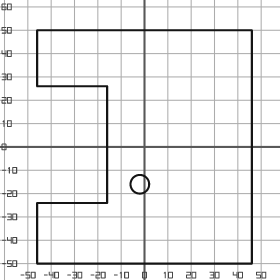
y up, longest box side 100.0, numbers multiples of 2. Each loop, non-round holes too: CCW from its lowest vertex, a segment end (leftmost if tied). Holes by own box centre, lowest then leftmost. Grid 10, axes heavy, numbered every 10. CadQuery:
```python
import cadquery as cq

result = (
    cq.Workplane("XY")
    .moveTo(-46.0, -50.0)
    .lineTo(46.0, -50.0)
    .lineTo(46.0, 50.0)
    .lineTo(-46.0, 50.0)
    .lineTo(-46.0, 26.0)
    .lineTo(-16.0, 26.0)
    .lineTo(-16.0, -24.0)
    .lineTo(-46.0, -24.0)
    .close()
    .moveTo(-2.0, -16.0)
    .circle(4.0)
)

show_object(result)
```